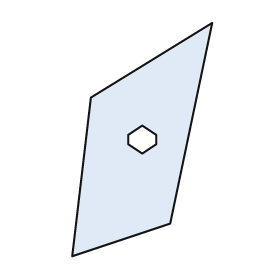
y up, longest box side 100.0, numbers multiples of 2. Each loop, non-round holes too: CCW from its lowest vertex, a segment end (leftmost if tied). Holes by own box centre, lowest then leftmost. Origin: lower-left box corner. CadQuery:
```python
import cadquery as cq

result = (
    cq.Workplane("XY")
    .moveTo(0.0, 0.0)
    .lineTo(42.0, 14.0)
    .lineTo(60.0, 100.0)
    .lineTo(8.0, 68.0)
    .close()
    .moveTo(30.0, 44.0)
    .lineTo(36.0, 48.0)
    .lineTo(36.0, 52.0)
    .lineTo(30.0, 56.0)
    .lineTo(24.0, 52.0)
    .lineTo(24.0, 48.0)
    .close()
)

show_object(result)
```